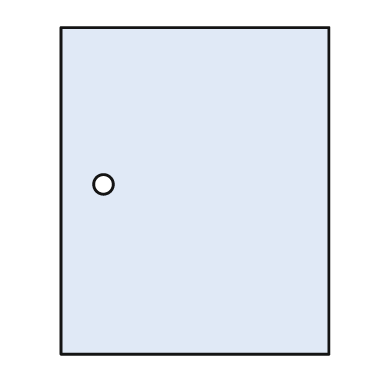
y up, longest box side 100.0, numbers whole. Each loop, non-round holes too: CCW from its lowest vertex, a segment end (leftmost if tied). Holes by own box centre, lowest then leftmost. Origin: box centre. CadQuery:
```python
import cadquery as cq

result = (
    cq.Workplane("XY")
    .moveTo(-41.0, -50.0)
    .lineTo(41.0, -50.0)
    .lineTo(41.0, 50.0)
    .lineTo(-41.0, 50.0)
    .close()
    .moveTo(-28.0, 2.0)
    .circle(3.0)
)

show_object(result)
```